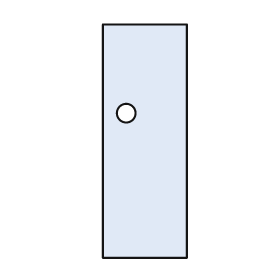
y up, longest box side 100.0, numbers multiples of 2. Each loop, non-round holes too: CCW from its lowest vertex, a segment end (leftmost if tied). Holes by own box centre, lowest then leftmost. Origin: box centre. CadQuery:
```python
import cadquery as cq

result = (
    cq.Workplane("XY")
    .moveTo(-18.0, -50.0)
    .lineTo(18.0, -50.0)
    .lineTo(18.0, 50.0)
    .lineTo(-18.0, 50.0)
    .close()
    .moveTo(-8.0, 12.0)
    .circle(4.0)
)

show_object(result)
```